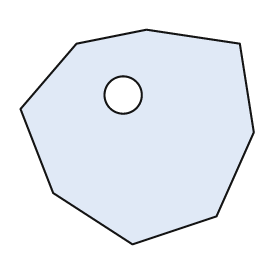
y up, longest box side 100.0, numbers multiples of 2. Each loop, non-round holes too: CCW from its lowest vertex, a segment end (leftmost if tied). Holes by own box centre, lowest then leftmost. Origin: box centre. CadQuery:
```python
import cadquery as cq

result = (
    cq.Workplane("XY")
    .moveTo(-2.0, -46.0)
    .lineTo(34.0, -34.0)
    .lineTo(50.0, 2.0)
    .lineTo(44.0, 40.0)
    .lineTo(4.0, 46.0)
    .lineTo(-26.0, 40.0)
    .lineTo(-50.0, 12.0)
    .lineTo(-36.0, -24.0)
    .close()
    .moveTo(-6.0, 18.0)
    .circle(8.0)
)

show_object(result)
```